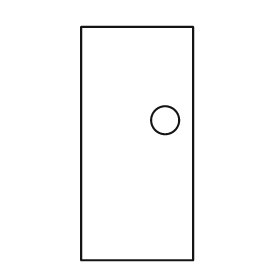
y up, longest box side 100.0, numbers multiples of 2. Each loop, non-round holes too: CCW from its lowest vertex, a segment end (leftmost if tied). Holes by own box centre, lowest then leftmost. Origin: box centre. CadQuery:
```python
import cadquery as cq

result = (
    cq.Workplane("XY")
    .moveTo(-24.0, -50.0)
    .lineTo(24.0, -50.0)
    .lineTo(24.0, 50.0)
    .lineTo(-24.0, 50.0)
    .close()
    .moveTo(12.0, 10.0)
    .circle(6.0)
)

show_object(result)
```